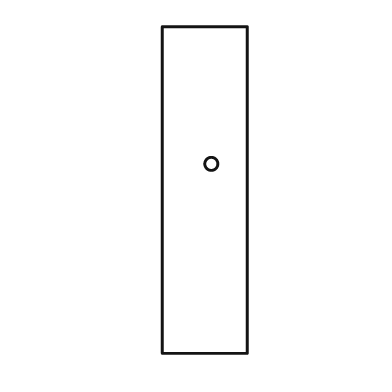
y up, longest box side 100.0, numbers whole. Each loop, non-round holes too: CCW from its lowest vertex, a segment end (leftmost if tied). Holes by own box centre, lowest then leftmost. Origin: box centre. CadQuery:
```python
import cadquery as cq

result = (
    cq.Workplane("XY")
    .moveTo(-13.0, -50.0)
    .lineTo(13.0, -50.0)
    .lineTo(13.0, 50.0)
    .lineTo(-13.0, 50.0)
    .close()
    .moveTo(2.0, 8.0)
    .circle(2.0)
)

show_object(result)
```